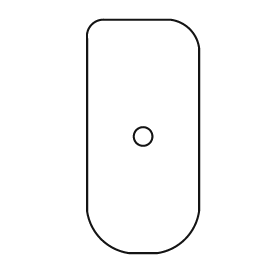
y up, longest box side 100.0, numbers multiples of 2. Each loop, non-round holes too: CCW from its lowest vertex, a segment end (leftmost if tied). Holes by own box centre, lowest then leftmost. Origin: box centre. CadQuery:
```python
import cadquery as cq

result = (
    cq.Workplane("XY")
    .moveTo(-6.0, -50.0)
    .lineTo(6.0, -50.0)
    .threePointArc((18.0, -44.0), (24.0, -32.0))
    .lineTo(24.0, 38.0)
    .threePointArc((20.0, 46.0), (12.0, 50.0))
    .lineTo(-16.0, 50.0)
    .threePointArc((-22.0, 48.0), (-24.0, 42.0))
    .lineTo(-24.0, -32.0)
    .threePointArc((-18.0, -44.0), (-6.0, -50.0))
    .close()
    .moveTo(0.0, 0.0)
    .circle(4.0)
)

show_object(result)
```